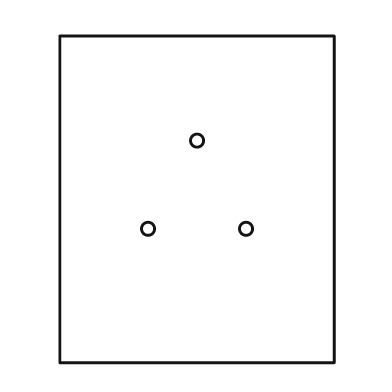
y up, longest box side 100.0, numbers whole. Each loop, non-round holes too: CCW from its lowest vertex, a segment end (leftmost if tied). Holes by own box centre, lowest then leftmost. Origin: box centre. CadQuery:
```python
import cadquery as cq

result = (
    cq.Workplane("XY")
    .moveTo(-42.0, -50.0)
    .lineTo(42.0, -50.0)
    .lineTo(42.0, 50.0)
    .lineTo(-42.0, 50.0)
    .close()
    .moveTo(-15.0, -9.0)
    .circle(2.0)
    .moveTo(15.0, -9.0)
    .circle(2.0)
    .moveTo(0.0, 18.0)
    .circle(2.0)
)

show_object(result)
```